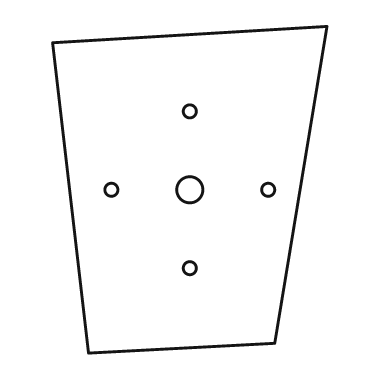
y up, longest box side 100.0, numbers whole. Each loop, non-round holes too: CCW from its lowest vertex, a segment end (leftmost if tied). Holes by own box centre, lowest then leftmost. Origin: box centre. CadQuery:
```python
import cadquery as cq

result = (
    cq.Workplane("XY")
    .moveTo(-31.0, -50.0)
    .lineTo(26.0, -47.0)
    .lineTo(42.0, 50.0)
    .lineTo(-42.0, 45.0)
    .close()
    .moveTo(0.0, -24.0)
    .circle(2.0)
    .moveTo(-24.0, 0.0)
    .circle(2.0)
    .moveTo(0.0, 0.0)
    .circle(4.0)
    .moveTo(24.0, 0.0)
    .circle(2.0)
    .moveTo(0.0, 24.0)
    .circle(2.0)
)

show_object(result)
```